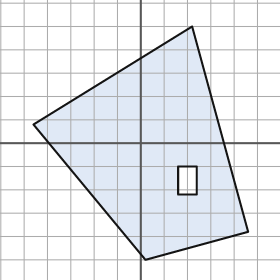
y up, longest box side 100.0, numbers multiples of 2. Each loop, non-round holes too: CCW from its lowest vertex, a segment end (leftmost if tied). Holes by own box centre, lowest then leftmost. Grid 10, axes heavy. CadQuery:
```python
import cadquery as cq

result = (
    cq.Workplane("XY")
    .moveTo(2.0, -50.0)
    .lineTo(46.0, -38.0)
    .lineTo(22.0, 50.0)
    .lineTo(-46.0, 8.0)
    .close()
    .moveTo(16.0, -22.0)
    .lineTo(24.0, -22.0)
    .lineTo(24.0, -10.0)
    .lineTo(16.0, -10.0)
    .close()
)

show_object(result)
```